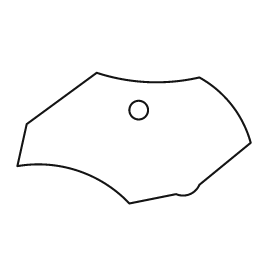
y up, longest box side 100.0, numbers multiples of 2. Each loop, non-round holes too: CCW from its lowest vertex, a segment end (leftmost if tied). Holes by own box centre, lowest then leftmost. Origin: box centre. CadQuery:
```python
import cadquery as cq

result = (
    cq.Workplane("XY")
    .moveTo(-2.0, -28.0)
    .lineTo(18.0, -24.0)
    .threePointArc((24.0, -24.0), (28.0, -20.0))
    .lineTo(50.0, -2.0)
    .threePointArc((42.0, 14.0), (28.0, 26.0))
    .threePointArc((6.0, 24.0), (-16.0, 28.0))
    .lineTo(-46.0, 6.0)
    .lineTo(-50.0, -12.0)
    .threePointArc((-24.0, -14.0), (-2.0, -28.0))
    .close()
    .moveTo(2.0, 12.0)
    .circle(4.0)
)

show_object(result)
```